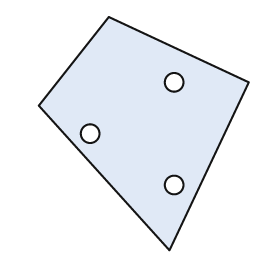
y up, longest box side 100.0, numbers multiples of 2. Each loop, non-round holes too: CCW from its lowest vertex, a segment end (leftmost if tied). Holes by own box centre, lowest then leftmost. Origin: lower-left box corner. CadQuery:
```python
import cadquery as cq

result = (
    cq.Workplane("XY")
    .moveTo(56.0, 0.0)
    .lineTo(90.0, 72.0)
    .lineTo(30.0, 100.0)
    .lineTo(0.0, 62.0)
    .close()
    .moveTo(58.0, 28.0)
    .circle(4.0)
    .moveTo(22.0, 50.0)
    .circle(4.0)
    .moveTo(58.0, 72.0)
    .circle(4.0)
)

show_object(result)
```